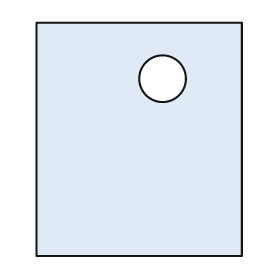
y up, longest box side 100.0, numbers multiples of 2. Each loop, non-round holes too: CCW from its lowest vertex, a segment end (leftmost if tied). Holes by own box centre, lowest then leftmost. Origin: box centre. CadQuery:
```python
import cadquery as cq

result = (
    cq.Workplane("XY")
    .moveTo(-44.0, -50.0)
    .lineTo(44.0, -50.0)
    .lineTo(44.0, 50.0)
    .lineTo(-44.0, 50.0)
    .close()
    .moveTo(10.0, 26.0)
    .circle(10.0)
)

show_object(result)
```